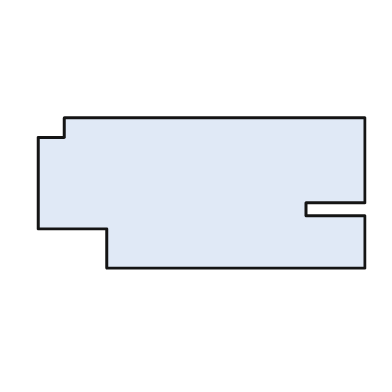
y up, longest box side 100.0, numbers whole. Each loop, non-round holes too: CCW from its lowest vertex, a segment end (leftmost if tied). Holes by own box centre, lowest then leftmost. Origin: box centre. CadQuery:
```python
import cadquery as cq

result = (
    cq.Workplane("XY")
    .moveTo(-29.0, -23.0)
    .lineTo(50.0, -23.0)
    .lineTo(50.0, -7.0)
    .lineTo(32.0, -7.0)
    .lineTo(32.0, -3.0)
    .lineTo(50.0, -3.0)
    .lineTo(50.0, 23.0)
    .lineTo(-42.0, 23.0)
    .lineTo(-42.0, 17.0)
    .lineTo(-50.0, 17.0)
    .lineTo(-50.0, -11.0)
    .lineTo(-29.0, -11.0)
    .close()
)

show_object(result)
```